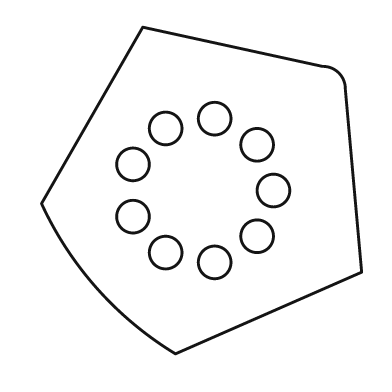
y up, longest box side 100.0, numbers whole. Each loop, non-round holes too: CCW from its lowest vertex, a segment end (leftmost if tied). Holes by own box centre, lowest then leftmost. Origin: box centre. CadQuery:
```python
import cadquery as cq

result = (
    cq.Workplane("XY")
    .moveTo(-8.0, -50.0)
    .lineTo(49.0, -25.0)
    .lineTo(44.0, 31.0)
    .threePointArc((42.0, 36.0), (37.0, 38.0))
    .lineTo(-18.0, 50.0)
    .lineTo(-49.0, -4.0)
    .threePointArc((-32.0, -30.0), (-8.0, -50.0))
    .close()
    .moveTo(4.0, -22.0)
    .circle(5.0)
    .moveTo(-11.0, -19.0)
    .circle(5.0)
    .moveTo(17.0, -14.0)
    .circle(5.0)
    .moveTo(-21.0, -8.0)
    .circle(5.0)
    .moveTo(22.0, 0.0)
    .circle(5.0)
    .moveTo(-21.0, 8.0)
    .circle(5.0)
    .moveTo(17.0, 14.0)
    .circle(5.0)
    .moveTo(-11.0, 19.0)
    .circle(5.0)
    .moveTo(4.0, 22.0)
    .circle(5.0)
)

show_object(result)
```